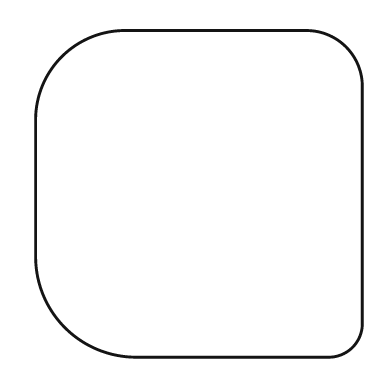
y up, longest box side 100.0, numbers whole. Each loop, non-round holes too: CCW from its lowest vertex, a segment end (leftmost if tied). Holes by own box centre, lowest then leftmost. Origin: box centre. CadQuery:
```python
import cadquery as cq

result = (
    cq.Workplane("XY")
    .moveTo(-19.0, -50.0)
    .lineTo(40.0, -50.0)
    .threePointArc((47.0, -47.0), (50.0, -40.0))
    .lineTo(50.0, 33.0)
    .threePointArc((45.0, 45.0), (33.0, 50.0))
    .lineTo(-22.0, 50.0)
    .threePointArc((-42.0, 42.0), (-50.0, 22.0))
    .lineTo(-50.0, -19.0)
    .threePointArc((-41.0, -41.0), (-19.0, -50.0))
    .close()
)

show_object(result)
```